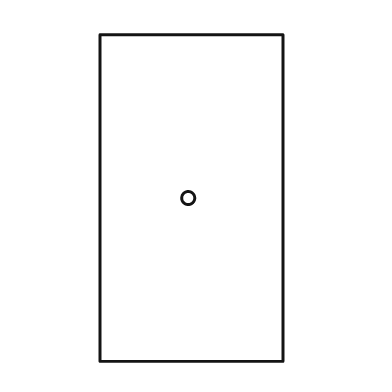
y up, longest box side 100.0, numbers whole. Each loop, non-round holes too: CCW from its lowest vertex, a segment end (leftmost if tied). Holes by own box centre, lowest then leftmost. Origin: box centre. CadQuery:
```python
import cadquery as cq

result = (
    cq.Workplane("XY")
    .moveTo(-28.0, -50.0)
    .lineTo(28.0, -50.0)
    .lineTo(28.0, 50.0)
    .lineTo(-28.0, 50.0)
    .close()
    .moveTo(-1.0, 0.0)
    .circle(2.0)
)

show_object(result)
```